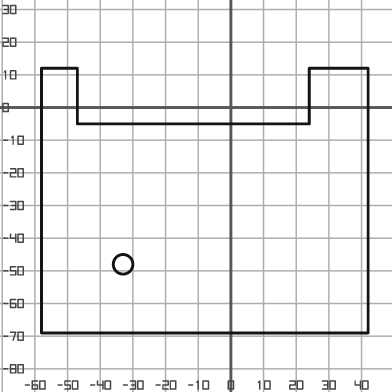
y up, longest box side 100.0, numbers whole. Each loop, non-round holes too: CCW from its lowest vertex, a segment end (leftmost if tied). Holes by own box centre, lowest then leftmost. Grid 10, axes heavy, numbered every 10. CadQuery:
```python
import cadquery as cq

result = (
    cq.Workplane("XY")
    .moveTo(-58.0, -69.0)
    .lineTo(42.0, -69.0)
    .lineTo(42.0, 12.0)
    .lineTo(24.0, 12.0)
    .lineTo(24.0, -5.0)
    .lineTo(-47.0, -5.0)
    .lineTo(-47.0, 12.0)
    .lineTo(-58.0, 12.0)
    .close()
    .moveTo(-33.0, -48.0)
    .circle(3.0)
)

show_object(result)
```